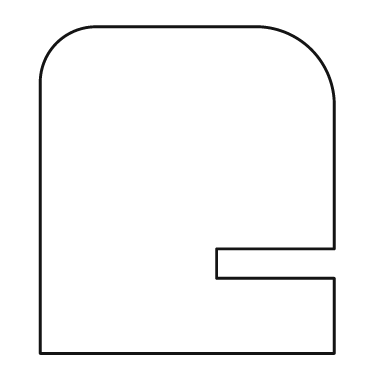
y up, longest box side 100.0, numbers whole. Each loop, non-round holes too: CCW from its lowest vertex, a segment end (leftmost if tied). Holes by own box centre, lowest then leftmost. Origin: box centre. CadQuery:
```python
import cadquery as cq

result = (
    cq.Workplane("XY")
    .moveTo(-45.0, -50.0)
    .lineTo(45.0, -50.0)
    .lineTo(45.0, -27.0)
    .lineTo(9.0, -27.0)
    .lineTo(9.0, -18.0)
    .lineTo(45.0, -18.0)
    .lineTo(45.0, 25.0)
    .threePointArc((38.0, 43.0), (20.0, 50.0))
    .lineTo(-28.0, 50.0)
    .threePointArc((-40.0, 45.0), (-45.0, 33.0))
    .close()
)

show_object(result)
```